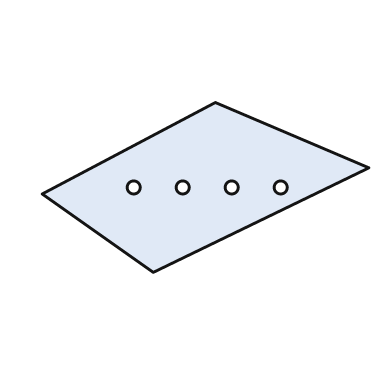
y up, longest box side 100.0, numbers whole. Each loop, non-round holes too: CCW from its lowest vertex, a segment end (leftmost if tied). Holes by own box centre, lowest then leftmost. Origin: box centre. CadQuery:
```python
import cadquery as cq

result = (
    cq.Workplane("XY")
    .moveTo(-16.0, -26.0)
    .lineTo(50.0, 6.0)
    .lineTo(3.0, 26.0)
    .lineTo(-50.0, -2.0)
    .close()
    .moveTo(-22.0, 0.0)
    .circle(2.0)
    .moveTo(-7.0, 0.0)
    .circle(2.0)
    .moveTo(8.0, 0.0)
    .circle(2.0)
    .moveTo(23.0, 0.0)
    .circle(2.0)
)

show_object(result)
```